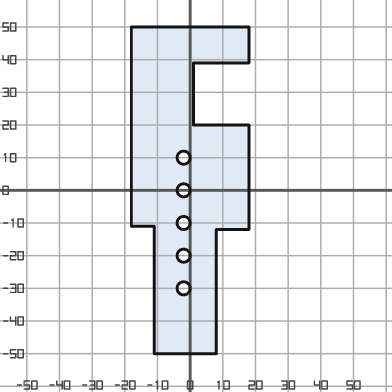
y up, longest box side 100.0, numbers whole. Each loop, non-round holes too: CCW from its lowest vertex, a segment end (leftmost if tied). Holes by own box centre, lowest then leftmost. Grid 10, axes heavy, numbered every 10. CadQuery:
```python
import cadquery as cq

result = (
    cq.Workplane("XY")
    .moveTo(-11.0, -50.0)
    .lineTo(8.0, -50.0)
    .lineTo(8.0, -12.0)
    .lineTo(18.0, -12.0)
    .lineTo(18.0, 20.0)
    .lineTo(1.0, 20.0)
    .lineTo(1.0, 39.0)
    .lineTo(18.0, 39.0)
    .lineTo(18.0, 50.0)
    .lineTo(-18.0, 50.0)
    .lineTo(-18.0, -11.0)
    .lineTo(-11.0, -11.0)
    .close()
    .moveTo(-2.0, -30.0)
    .circle(2.0)
    .moveTo(-2.0, -20.0)
    .circle(2.0)
    .moveTo(-2.0, -10.0)
    .circle(2.0)
    .moveTo(-2.0, 0.0)
    .circle(2.0)
    .moveTo(-2.0, 10.0)
    .circle(2.0)
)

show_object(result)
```